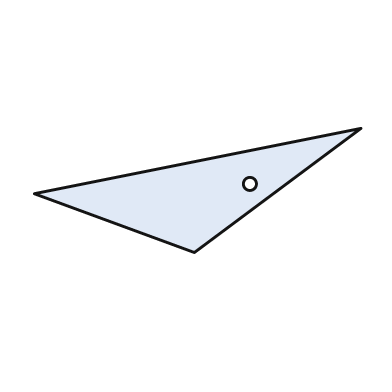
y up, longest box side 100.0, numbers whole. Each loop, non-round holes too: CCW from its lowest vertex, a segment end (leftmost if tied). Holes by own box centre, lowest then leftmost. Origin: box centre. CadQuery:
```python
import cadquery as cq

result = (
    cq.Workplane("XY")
    .moveTo(-1.0, -19.0)
    .lineTo(50.0, 19.0)
    .lineTo(-50.0, -1.0)
    .close()
    .moveTo(16.0, 2.0)
    .circle(2.0)
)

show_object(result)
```